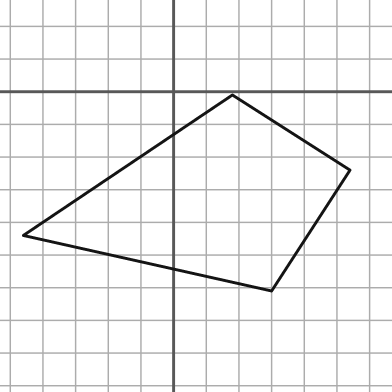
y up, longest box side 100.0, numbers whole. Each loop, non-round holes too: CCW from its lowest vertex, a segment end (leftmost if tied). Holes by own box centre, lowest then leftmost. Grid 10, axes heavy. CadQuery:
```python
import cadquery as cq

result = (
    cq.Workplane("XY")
    .moveTo(30.0, -61.0)
    .lineTo(54.0, -24.0)
    .lineTo(18.0, -1.0)
    .lineTo(-46.0, -44.0)
    .close()
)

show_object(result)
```